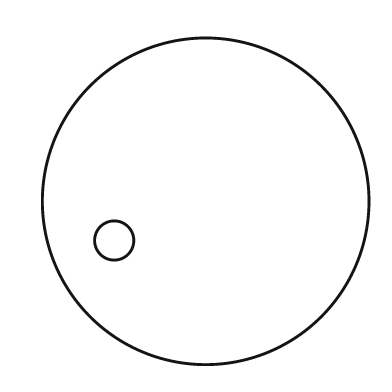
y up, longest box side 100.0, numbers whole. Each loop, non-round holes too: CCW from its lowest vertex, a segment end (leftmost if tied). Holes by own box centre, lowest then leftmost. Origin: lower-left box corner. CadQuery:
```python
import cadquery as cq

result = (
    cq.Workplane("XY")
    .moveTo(50.0, 50.0)
    .circle(50.0)
    .moveTo(22.0, 38.0)
    .circle(6.0)
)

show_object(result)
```